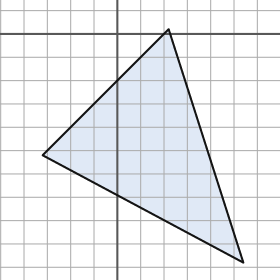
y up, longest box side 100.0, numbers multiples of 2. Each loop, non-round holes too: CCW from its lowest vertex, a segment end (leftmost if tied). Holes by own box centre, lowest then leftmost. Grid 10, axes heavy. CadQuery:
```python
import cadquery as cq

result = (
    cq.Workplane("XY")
    .moveTo(54.0, -98.0)
    .lineTo(22.0, 2.0)
    .lineTo(-32.0, -52.0)
    .close()
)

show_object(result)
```